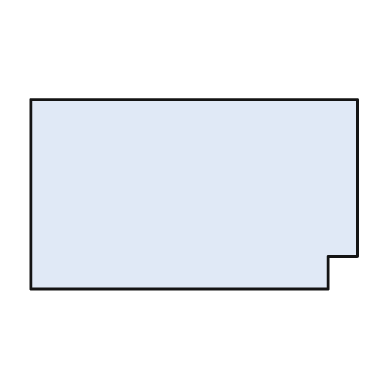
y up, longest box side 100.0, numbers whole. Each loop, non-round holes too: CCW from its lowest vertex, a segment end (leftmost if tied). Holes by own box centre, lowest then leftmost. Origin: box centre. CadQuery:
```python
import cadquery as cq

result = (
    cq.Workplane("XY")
    .moveTo(-50.0, -29.0)
    .lineTo(41.0, -29.0)
    .lineTo(41.0, -19.0)
    .lineTo(50.0, -19.0)
    .lineTo(50.0, 29.0)
    .lineTo(-50.0, 29.0)
    .close()
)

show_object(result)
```